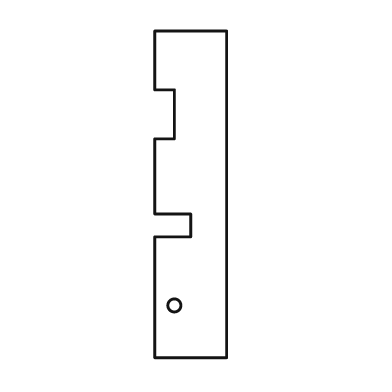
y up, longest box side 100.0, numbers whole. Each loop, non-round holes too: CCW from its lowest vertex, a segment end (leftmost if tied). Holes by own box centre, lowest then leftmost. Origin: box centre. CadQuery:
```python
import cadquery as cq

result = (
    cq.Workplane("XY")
    .moveTo(-11.0, -50.0)
    .lineTo(11.0, -50.0)
    .lineTo(11.0, 50.0)
    .lineTo(-11.0, 50.0)
    .lineTo(-11.0, 32.0)
    .lineTo(-5.0, 32.0)
    .lineTo(-5.0, 17.0)
    .lineTo(-11.0, 17.0)
    .lineTo(-11.0, -6.0)
    .lineTo(0.0, -6.0)
    .lineTo(0.0, -13.0)
    .lineTo(-11.0, -13.0)
    .close()
    .moveTo(-5.0, -34.0)
    .circle(2.0)
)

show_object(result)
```